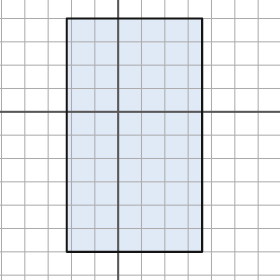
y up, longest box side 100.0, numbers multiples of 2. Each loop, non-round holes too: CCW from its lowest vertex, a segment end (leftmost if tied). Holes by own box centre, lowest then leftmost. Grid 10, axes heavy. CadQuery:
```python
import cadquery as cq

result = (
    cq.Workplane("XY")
    .moveTo(-22.0, -60.0)
    .lineTo(36.0, -60.0)
    .lineTo(36.0, 40.0)
    .lineTo(-22.0, 40.0)
    .close()
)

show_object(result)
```